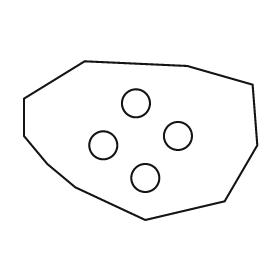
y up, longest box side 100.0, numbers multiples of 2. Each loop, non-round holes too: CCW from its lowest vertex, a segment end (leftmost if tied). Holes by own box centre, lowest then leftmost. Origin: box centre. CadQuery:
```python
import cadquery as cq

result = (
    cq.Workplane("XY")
    .moveTo(2.0, -34.0)
    .lineTo(36.0, -26.0)
    .lineTo(50.0, -2.0)
    .lineTo(48.0, 24.0)
    .lineTo(20.0, 32.0)
    .lineTo(-24.0, 34.0)
    .lineTo(-50.0, 18.0)
    .lineTo(-50.0, 2.0)
    .lineTo(-40.0, -10.0)
    .lineTo(-28.0, -20.0)
    .close()
    .moveTo(2.0, -16.0)
    .circle(6.0)
    .moveTo(-16.0, -2.0)
    .circle(6.0)
    .moveTo(16.0, 2.0)
    .circle(6.0)
    .moveTo(-2.0, 16.0)
    .circle(6.0)
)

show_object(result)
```